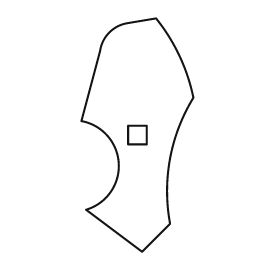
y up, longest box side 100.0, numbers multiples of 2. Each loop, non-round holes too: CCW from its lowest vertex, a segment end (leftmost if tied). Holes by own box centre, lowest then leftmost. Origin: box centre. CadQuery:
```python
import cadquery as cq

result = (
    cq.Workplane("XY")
    .moveTo(2.0, -50.0)
    .lineTo(14.0, -38.0)
    .threePointArc((14.0, -10.0), (24.0, 16.0))
    .threePointArc((18.0, 34.0), (8.0, 50.0))
    .lineTo(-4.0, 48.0)
    .threePointArc((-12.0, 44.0), (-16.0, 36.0))
    .lineTo(-24.0, 6.0)
    .threePointArc((-8.0, -12.0), (-22.0, -32.0))
    .close()
    .moveTo(-4.0, -4.0)
    .lineTo(4.0, -4.0)
    .lineTo(4.0, 4.0)
    .lineTo(-4.0, 4.0)
    .close()
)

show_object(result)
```